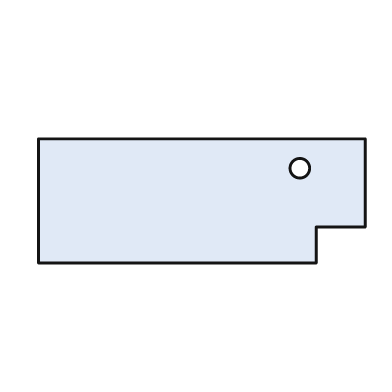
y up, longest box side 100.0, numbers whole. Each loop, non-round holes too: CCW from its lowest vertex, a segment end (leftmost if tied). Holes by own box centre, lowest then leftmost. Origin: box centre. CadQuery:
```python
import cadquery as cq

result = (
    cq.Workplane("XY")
    .moveTo(-50.0, -19.0)
    .lineTo(35.0, -19.0)
    .lineTo(35.0, -8.0)
    .lineTo(50.0, -8.0)
    .lineTo(50.0, 19.0)
    .lineTo(-50.0, 19.0)
    .close()
    .moveTo(30.0, 10.0)
    .circle(3.0)
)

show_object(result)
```